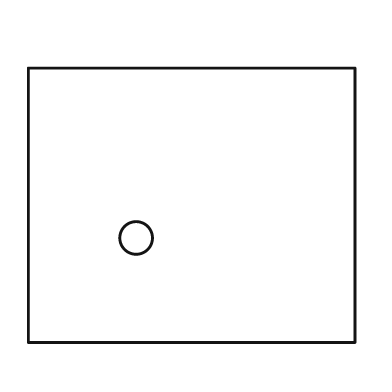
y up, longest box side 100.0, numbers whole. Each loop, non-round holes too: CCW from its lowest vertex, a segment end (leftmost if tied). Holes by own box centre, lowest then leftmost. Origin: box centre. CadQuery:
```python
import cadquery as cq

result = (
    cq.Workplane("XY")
    .moveTo(-50.0, -42.0)
    .lineTo(50.0, -42.0)
    .lineTo(50.0, 42.0)
    .lineTo(-50.0, 42.0)
    .close()
    .moveTo(-17.0, -10.0)
    .circle(5.0)
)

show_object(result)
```